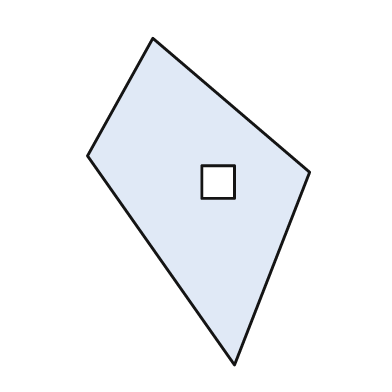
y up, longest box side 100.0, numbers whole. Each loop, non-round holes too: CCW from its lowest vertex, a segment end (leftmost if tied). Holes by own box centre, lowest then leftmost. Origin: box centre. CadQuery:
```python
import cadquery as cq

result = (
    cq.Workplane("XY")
    .moveTo(11.0, -50.0)
    .lineTo(34.0, 9.0)
    .lineTo(-14.0, 50.0)
    .lineTo(-34.0, 14.0)
    .close()
    .moveTo(1.0, 1.0)
    .lineTo(11.0, 1.0)
    .lineTo(11.0, 11.0)
    .lineTo(1.0, 11.0)
    .close()
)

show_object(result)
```